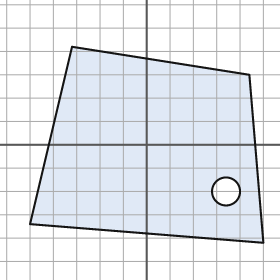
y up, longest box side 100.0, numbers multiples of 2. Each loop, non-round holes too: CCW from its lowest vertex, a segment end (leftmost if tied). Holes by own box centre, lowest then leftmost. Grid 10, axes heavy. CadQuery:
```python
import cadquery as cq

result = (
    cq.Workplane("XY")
    .moveTo(50.0, -42.0)
    .lineTo(44.0, 30.0)
    .lineTo(-32.0, 42.0)
    .lineTo(-50.0, -34.0)
    .close()
    .moveTo(34.0, -20.0)
    .circle(6.0)
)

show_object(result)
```